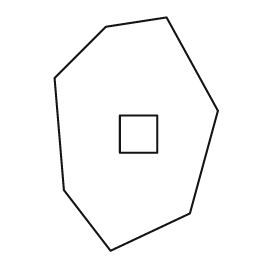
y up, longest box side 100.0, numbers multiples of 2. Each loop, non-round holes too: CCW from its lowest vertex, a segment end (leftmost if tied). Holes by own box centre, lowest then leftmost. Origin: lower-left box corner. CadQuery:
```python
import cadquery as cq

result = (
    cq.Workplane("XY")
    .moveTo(24.0, 0.0)
    .lineTo(58.0, 16.0)
    .lineTo(70.0, 60.0)
    .lineTo(48.0, 100.0)
    .lineTo(22.0, 96.0)
    .lineTo(0.0, 74.0)
    .lineTo(4.0, 26.0)
    .close()
    .moveTo(28.0, 42.0)
    .lineTo(44.0, 42.0)
    .lineTo(44.0, 58.0)
    .lineTo(28.0, 58.0)
    .close()
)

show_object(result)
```